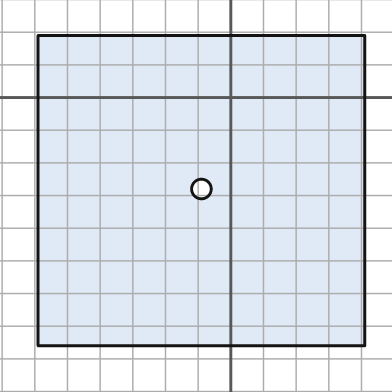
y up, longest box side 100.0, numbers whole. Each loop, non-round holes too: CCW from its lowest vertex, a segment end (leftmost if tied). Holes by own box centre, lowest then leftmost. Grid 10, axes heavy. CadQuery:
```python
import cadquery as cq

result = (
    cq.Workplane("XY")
    .moveTo(-59.0, -76.0)
    .lineTo(41.0, -76.0)
    .lineTo(41.0, 19.0)
    .lineTo(-59.0, 19.0)
    .close()
    .moveTo(-9.0, -28.0)
    .circle(3.0)
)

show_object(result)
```